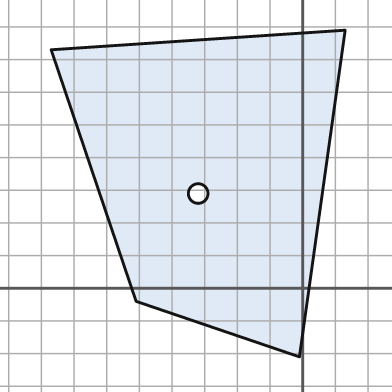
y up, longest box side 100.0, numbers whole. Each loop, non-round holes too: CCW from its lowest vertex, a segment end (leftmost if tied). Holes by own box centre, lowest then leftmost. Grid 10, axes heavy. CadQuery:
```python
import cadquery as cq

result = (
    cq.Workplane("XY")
    .moveTo(-1.0, -21.0)
    .lineTo(13.0, 79.0)
    .lineTo(-77.0, 73.0)
    .lineTo(-51.0, -4.0)
    .close()
    .moveTo(-32.0, 29.0)
    .circle(3.0)
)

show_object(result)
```